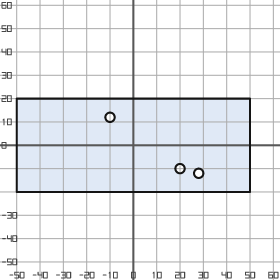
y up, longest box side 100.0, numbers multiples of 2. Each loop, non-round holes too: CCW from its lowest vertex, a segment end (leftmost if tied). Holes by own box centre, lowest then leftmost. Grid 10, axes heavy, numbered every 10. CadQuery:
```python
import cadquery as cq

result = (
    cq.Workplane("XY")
    .moveTo(-50.0, -20.0)
    .lineTo(50.0, -20.0)
    .lineTo(50.0, 20.0)
    .lineTo(-50.0, 20.0)
    .close()
    .moveTo(28.0, -12.0)
    .circle(2.0)
    .moveTo(20.0, -10.0)
    .circle(2.0)
    .moveTo(-10.0, 12.0)
    .circle(2.0)
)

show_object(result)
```